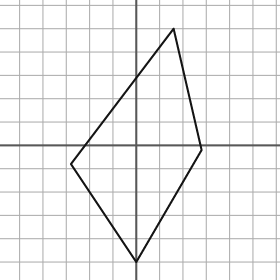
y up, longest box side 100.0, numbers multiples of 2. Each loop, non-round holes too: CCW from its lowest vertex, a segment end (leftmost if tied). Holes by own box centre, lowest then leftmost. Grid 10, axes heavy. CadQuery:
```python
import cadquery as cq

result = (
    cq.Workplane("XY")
    .moveTo(0.0, -50.0)
    .lineTo(28.0, -2.0)
    .lineTo(16.0, 50.0)
    .lineTo(-28.0, -8.0)
    .close()
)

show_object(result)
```